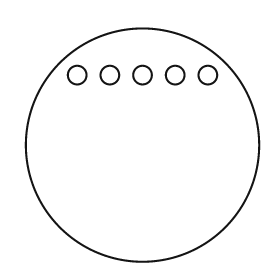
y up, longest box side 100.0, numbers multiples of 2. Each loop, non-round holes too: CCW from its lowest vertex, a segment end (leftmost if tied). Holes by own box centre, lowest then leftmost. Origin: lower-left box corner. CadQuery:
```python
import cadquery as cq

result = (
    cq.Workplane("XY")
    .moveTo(50.0, 50.0)
    .circle(50.0)
    .moveTo(22.0, 80.0)
    .circle(4.0)
    .moveTo(36.0, 80.0)
    .circle(4.0)
    .moveTo(50.0, 80.0)
    .circle(4.0)
    .moveTo(64.0, 80.0)
    .circle(4.0)
    .moveTo(78.0, 80.0)
    .circle(4.0)
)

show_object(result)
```